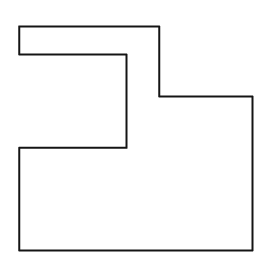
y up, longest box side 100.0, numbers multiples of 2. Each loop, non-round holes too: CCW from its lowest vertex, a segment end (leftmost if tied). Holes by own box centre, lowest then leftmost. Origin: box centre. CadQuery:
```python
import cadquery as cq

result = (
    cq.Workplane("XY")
    .moveTo(-50.0, -48.0)
    .lineTo(50.0, -48.0)
    .lineTo(50.0, 18.0)
    .lineTo(10.0, 18.0)
    .lineTo(10.0, 48.0)
    .lineTo(-50.0, 48.0)
    .lineTo(-50.0, 36.0)
    .lineTo(-4.0, 36.0)
    .lineTo(-4.0, -4.0)
    .lineTo(-50.0, -4.0)
    .close()
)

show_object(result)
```